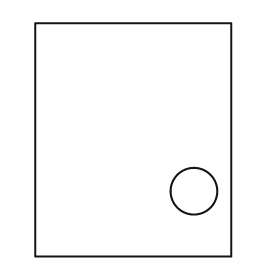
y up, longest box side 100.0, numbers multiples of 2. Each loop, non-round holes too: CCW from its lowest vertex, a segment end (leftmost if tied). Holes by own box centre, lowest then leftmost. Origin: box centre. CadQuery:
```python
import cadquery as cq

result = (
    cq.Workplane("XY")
    .moveTo(-42.0, -50.0)
    .lineTo(42.0, -50.0)
    .lineTo(42.0, 50.0)
    .lineTo(-42.0, 50.0)
    .close()
    .moveTo(26.0, -22.0)
    .circle(10.0)
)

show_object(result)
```